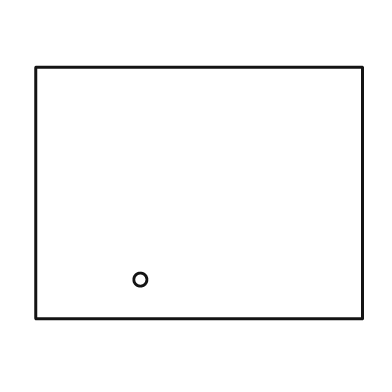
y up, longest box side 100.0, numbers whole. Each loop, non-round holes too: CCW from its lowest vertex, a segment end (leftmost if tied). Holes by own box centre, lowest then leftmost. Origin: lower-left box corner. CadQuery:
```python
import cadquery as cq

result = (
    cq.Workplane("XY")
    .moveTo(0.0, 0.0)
    .lineTo(100.0, 0.0)
    .lineTo(100.0, 77.0)
    .lineTo(0.0, 77.0)
    .close()
    .moveTo(32.0, 12.0)
    .circle(2.0)
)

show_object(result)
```